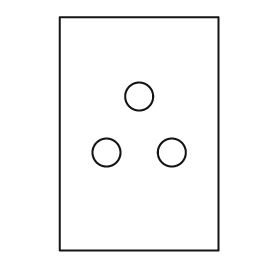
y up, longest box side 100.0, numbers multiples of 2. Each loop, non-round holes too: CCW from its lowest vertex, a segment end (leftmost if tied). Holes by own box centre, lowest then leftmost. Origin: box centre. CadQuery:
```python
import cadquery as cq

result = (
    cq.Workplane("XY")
    .moveTo(-34.0, -50.0)
    .lineTo(34.0, -50.0)
    .lineTo(34.0, 50.0)
    .lineTo(-34.0, 50.0)
    .close()
    .moveTo(-14.0, -8.0)
    .circle(6.0)
    .moveTo(14.0, -8.0)
    .circle(6.0)
    .moveTo(0.0, 16.0)
    .circle(6.0)
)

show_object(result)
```